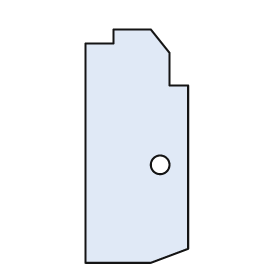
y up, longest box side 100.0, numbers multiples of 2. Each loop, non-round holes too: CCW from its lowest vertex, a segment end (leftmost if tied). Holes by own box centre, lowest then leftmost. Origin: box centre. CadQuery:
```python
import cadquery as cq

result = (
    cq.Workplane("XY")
    .moveTo(-22.0, -50.0)
    .lineTo(6.0, -50.0)
    .lineTo(22.0, -44.0)
    .lineTo(22.0, 26.0)
    .lineTo(14.0, 26.0)
    .lineTo(14.0, 40.0)
    .lineTo(6.0, 50.0)
    .lineTo(-10.0, 50.0)
    .lineTo(-10.0, 44.0)
    .lineTo(-22.0, 44.0)
    .close()
    .moveTo(10.0, -8.0)
    .circle(4.0)
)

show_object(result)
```